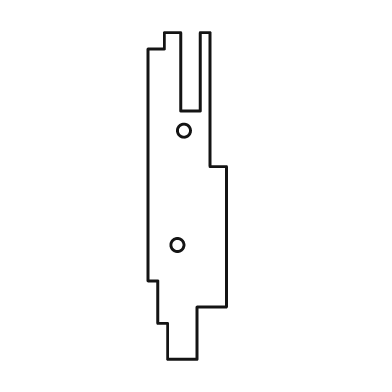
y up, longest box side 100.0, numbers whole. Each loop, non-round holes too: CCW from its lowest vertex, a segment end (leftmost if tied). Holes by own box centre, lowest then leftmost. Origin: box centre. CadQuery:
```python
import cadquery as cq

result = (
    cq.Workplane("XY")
    .moveTo(-6.0, -50.0)
    .lineTo(3.0, -50.0)
    .lineTo(3.0, -34.0)
    .lineTo(12.0, -34.0)
    .lineTo(12.0, 9.0)
    .lineTo(7.0, 9.0)
    .lineTo(7.0, 50.0)
    .lineTo(4.0, 50.0)
    .lineTo(4.0, 26.0)
    .lineTo(-2.0, 26.0)
    .lineTo(-2.0, 50.0)
    .lineTo(-7.0, 50.0)
    .lineTo(-7.0, 45.0)
    .lineTo(-12.0, 45.0)
    .lineTo(-12.0, -26.0)
    .lineTo(-9.0, -26.0)
    .lineTo(-9.0, -39.0)
    .lineTo(-6.0, -39.0)
    .close()
    .moveTo(-3.0, -15.0)
    .circle(2.0)
    .moveTo(-1.0, 20.0)
    .circle(2.0)
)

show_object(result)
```